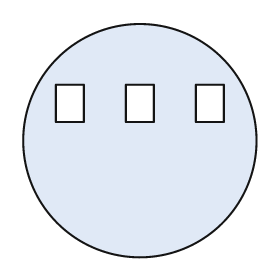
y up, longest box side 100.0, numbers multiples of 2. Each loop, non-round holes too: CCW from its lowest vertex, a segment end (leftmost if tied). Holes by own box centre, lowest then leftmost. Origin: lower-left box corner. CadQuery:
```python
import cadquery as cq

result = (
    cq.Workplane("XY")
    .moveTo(50.0, 50.0)
    .circle(50.0)
    .moveTo(14.0, 58.0)
    .lineTo(26.0, 58.0)
    .lineTo(26.0, 74.0)
    .lineTo(14.0, 74.0)
    .close()
    .moveTo(44.0, 58.0)
    .lineTo(56.0, 58.0)
    .lineTo(56.0, 74.0)
    .lineTo(44.0, 74.0)
    .close()
    .moveTo(74.0, 58.0)
    .lineTo(86.0, 58.0)
    .lineTo(86.0, 74.0)
    .lineTo(74.0, 74.0)
    .close()
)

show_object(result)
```